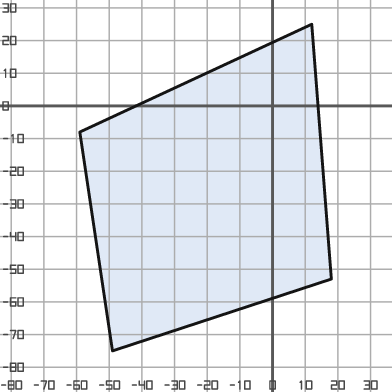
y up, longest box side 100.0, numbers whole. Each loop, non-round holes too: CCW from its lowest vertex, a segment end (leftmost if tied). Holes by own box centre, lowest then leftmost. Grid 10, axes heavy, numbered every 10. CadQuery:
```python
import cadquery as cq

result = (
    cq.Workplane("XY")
    .moveTo(-49.0, -75.0)
    .lineTo(18.0, -53.0)
    .lineTo(12.0, 25.0)
    .lineTo(-59.0, -8.0)
    .close()
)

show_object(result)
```